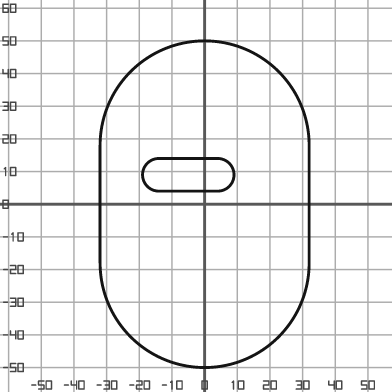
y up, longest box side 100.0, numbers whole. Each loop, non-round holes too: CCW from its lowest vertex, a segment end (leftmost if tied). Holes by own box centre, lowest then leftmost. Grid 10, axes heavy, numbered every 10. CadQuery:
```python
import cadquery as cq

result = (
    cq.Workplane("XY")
    .moveTo(-32.0, -18.0)
    .threePointArc((0.0, -50.0), (32.0, -18.0))
    .lineTo(32.0, 18.0)
    .threePointArc((0.0, 50.0), (-32.0, 18.0))
    .close()
    .moveTo(-14.0, 4.0)
    .lineTo(4.0, 4.0)
    .threePointArc((9.0, 9.0), (4.0, 14.0))
    .lineTo(-14.0, 14.0)
    .threePointArc((-19.0, 9.0), (-14.0, 4.0))
    .close()
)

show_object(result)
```